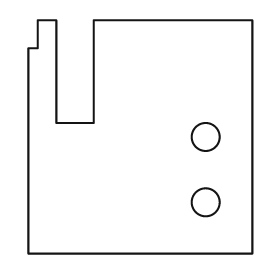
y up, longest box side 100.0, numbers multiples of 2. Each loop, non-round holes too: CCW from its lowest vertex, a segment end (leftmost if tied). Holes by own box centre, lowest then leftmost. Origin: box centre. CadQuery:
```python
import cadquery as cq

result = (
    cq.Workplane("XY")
    .moveTo(-48.0, -50.0)
    .lineTo(48.0, -50.0)
    .lineTo(48.0, 50.0)
    .lineTo(-20.0, 50.0)
    .lineTo(-20.0, 6.0)
    .lineTo(-36.0, 6.0)
    .lineTo(-36.0, 50.0)
    .lineTo(-44.0, 50.0)
    .lineTo(-44.0, 38.0)
    .lineTo(-48.0, 38.0)
    .close()
    .moveTo(28.0, -28.0)
    .circle(6.0)
    .moveTo(28.0, 0.0)
    .circle(6.0)
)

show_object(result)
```